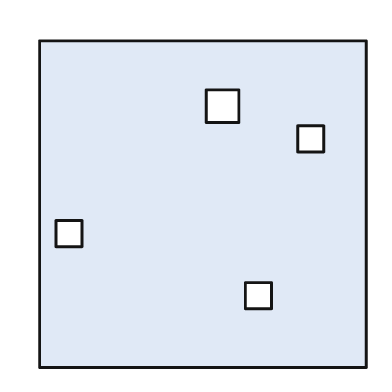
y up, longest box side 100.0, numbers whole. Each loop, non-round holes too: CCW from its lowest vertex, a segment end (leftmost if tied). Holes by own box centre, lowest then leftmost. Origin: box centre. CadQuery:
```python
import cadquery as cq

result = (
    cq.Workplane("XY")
    .moveTo(-50.0, -50.0)
    .lineTo(50.0, -50.0)
    .lineTo(50.0, 50.0)
    .lineTo(-50.0, 50.0)
    .close()
    .moveTo(13.0, -32.0)
    .lineTo(21.0, -32.0)
    .lineTo(21.0, -24.0)
    .lineTo(13.0, -24.0)
    .close()
    .moveTo(-45.0, -13.0)
    .lineTo(-37.0, -13.0)
    .lineTo(-37.0, -5.0)
    .lineTo(-45.0, -5.0)
    .close()
    .moveTo(29.0, 16.0)
    .lineTo(37.0, 16.0)
    .lineTo(37.0, 24.0)
    .lineTo(29.0, 24.0)
    .close()
    .moveTo(1.0, 25.0)
    .lineTo(11.0, 25.0)
    .lineTo(11.0, 35.0)
    .lineTo(1.0, 35.0)
    .close()
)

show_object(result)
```